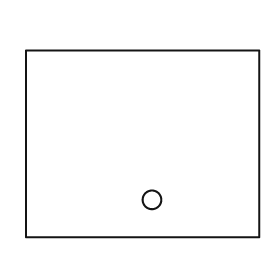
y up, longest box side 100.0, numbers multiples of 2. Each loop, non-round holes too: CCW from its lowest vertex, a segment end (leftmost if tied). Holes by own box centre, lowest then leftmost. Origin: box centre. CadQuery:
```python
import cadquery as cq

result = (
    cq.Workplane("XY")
    .moveTo(-50.0, -40.0)
    .lineTo(50.0, -40.0)
    .lineTo(50.0, 40.0)
    .lineTo(-50.0, 40.0)
    .close()
    .moveTo(4.0, -24.0)
    .circle(4.0)
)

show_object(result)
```